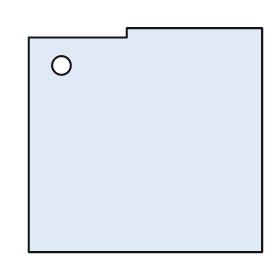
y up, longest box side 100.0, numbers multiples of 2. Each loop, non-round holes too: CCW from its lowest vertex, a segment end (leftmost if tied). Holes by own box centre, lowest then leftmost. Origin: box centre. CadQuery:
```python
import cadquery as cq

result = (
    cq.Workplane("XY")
    .moveTo(-50.0, -48.0)
    .lineTo(50.0, -48.0)
    .lineTo(50.0, 48.0)
    .lineTo(-8.0, 48.0)
    .lineTo(-8.0, 44.0)
    .lineTo(-50.0, 44.0)
    .close()
    .moveTo(-36.0, 32.0)
    .circle(4.0)
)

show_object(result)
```